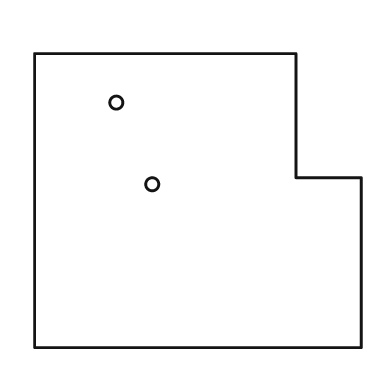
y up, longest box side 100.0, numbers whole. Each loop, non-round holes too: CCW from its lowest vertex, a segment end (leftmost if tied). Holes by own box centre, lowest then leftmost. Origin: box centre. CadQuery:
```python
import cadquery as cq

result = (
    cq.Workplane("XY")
    .moveTo(-50.0, -45.0)
    .lineTo(50.0, -45.0)
    .lineTo(50.0, 7.0)
    .lineTo(30.0, 7.0)
    .lineTo(30.0, 45.0)
    .lineTo(-50.0, 45.0)
    .close()
    .moveTo(-14.0, 5.0)
    .circle(2.0)
    .moveTo(-25.0, 30.0)
    .circle(2.0)
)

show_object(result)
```